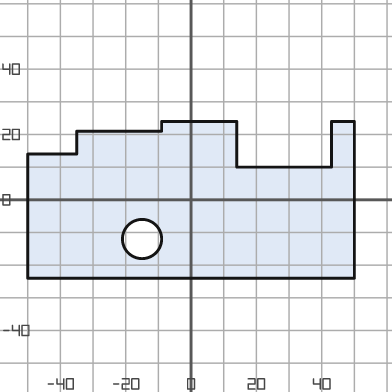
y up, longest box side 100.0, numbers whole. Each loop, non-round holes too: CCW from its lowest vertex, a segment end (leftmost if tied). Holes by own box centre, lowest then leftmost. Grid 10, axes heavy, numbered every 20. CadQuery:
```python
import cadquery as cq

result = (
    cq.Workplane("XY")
    .moveTo(-50.0, -24.0)
    .lineTo(50.0, -24.0)
    .lineTo(50.0, 24.0)
    .lineTo(43.0, 24.0)
    .lineTo(43.0, 10.0)
    .lineTo(14.0, 10.0)
    .lineTo(14.0, 24.0)
    .lineTo(-9.0, 24.0)
    .lineTo(-9.0, 21.0)
    .lineTo(-35.0, 21.0)
    .lineTo(-35.0, 14.0)
    .lineTo(-50.0, 14.0)
    .close()
    .moveTo(-15.0, -12.0)
    .circle(6.0)
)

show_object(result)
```